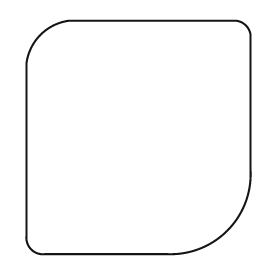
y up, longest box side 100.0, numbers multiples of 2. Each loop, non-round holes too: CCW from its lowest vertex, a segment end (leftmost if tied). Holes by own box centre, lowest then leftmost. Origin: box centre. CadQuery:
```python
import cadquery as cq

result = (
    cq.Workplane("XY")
    .moveTo(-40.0, -50.0)
    .lineTo(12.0, -50.0)
    .threePointArc((38.0, -40.0), (48.0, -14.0))
    .lineTo(48.0, 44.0)
    .threePointArc((46.0, 48.0), (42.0, 50.0))
    .lineTo(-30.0, 50.0)
    .threePointArc((-42.0, 44.0), (-48.0, 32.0))
    .lineTo(-48.0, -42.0)
    .threePointArc((-46.0, -48.0), (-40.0, -50.0))
    .close()
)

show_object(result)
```